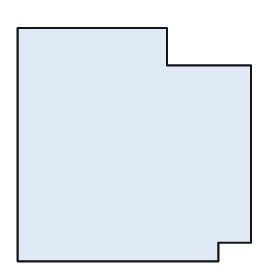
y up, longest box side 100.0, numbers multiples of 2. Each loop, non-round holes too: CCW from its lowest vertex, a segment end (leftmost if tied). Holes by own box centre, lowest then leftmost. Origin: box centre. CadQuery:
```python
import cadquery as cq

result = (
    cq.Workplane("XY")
    .moveTo(-50.0, -50.0)
    .lineTo(36.0, -50.0)
    .lineTo(36.0, -42.0)
    .lineTo(50.0, -42.0)
    .lineTo(50.0, 34.0)
    .lineTo(14.0, 34.0)
    .lineTo(14.0, 50.0)
    .lineTo(-50.0, 50.0)
    .close()
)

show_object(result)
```